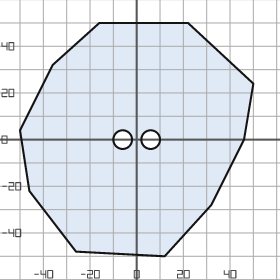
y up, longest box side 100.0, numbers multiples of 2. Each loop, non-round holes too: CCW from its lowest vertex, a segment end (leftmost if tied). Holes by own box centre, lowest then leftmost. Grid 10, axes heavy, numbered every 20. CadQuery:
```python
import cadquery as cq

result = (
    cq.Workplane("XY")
    .moveTo(12.0, -50.0)
    .lineTo(32.0, -28.0)
    .lineTo(46.0, 0.0)
    .lineTo(50.0, 24.0)
    .lineTo(22.0, 50.0)
    .lineTo(-16.0, 50.0)
    .lineTo(-36.0, 32.0)
    .lineTo(-50.0, 4.0)
    .lineTo(-46.0, -22.0)
    .lineTo(-26.0, -48.0)
    .close()
    .moveTo(-6.0, 0.0)
    .circle(4.0)
    .moveTo(6.0, 0.0)
    .circle(4.0)
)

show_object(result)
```